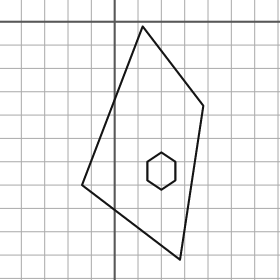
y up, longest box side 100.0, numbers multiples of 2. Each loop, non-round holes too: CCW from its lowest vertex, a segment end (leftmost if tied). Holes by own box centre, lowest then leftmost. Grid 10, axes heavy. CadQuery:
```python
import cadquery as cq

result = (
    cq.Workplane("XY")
    .moveTo(28.0, -102.0)
    .lineTo(38.0, -36.0)
    .lineTo(12.0, -2.0)
    .lineTo(-14.0, -70.0)
    .close()
    .moveTo(20.0, -72.0)
    .lineTo(26.0, -68.0)
    .lineTo(26.0, -60.0)
    .lineTo(20.0, -56.0)
    .lineTo(14.0, -60.0)
    .lineTo(14.0, -68.0)
    .close()
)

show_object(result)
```